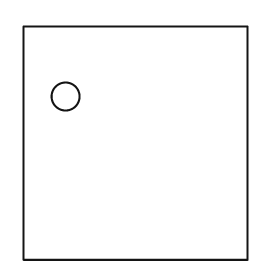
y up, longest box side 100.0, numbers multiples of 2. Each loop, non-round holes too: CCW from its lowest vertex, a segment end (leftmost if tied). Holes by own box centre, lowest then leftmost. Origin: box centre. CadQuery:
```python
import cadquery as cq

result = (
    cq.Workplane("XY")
    .moveTo(-48.0, -50.0)
    .lineTo(48.0, -50.0)
    .lineTo(48.0, 50.0)
    .lineTo(-48.0, 50.0)
    .close()
    .moveTo(-30.0, 20.0)
    .circle(6.0)
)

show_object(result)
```